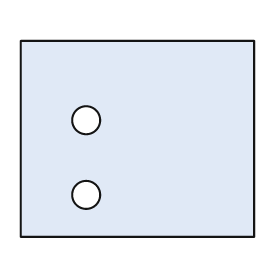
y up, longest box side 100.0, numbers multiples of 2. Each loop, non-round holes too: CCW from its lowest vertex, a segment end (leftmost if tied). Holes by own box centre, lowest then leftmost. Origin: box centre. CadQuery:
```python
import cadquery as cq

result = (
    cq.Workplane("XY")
    .moveTo(-50.0, -42.0)
    .lineTo(50.0, -42.0)
    .lineTo(50.0, 42.0)
    .lineTo(-50.0, 42.0)
    .close()
    .moveTo(-22.0, -24.0)
    .circle(6.0)
    .moveTo(-22.0, 8.0)
    .circle(6.0)
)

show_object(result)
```